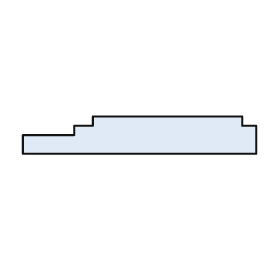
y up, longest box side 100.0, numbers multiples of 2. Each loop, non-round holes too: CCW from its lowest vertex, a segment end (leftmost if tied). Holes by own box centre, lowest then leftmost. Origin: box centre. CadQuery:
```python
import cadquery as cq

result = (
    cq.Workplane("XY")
    .moveTo(-50.0, -8.0)
    .lineTo(50.0, -8.0)
    .lineTo(50.0, 4.0)
    .lineTo(44.0, 4.0)
    .lineTo(44.0, 8.0)
    .lineTo(-20.0, 8.0)
    .lineTo(-20.0, 4.0)
    .lineTo(-28.0, 4.0)
    .lineTo(-28.0, 0.0)
    .lineTo(-50.0, 0.0)
    .close()
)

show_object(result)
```